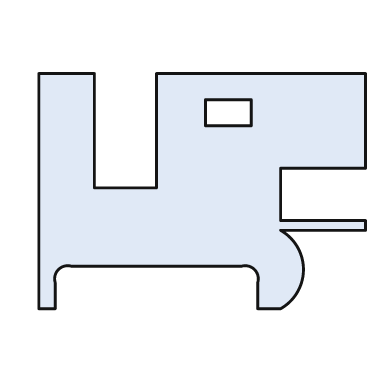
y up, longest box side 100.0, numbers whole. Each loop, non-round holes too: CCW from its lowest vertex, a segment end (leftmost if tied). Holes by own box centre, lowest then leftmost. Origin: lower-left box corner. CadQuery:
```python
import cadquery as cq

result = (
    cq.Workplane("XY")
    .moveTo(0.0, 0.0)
    .lineTo(5.0, 0.0)
    .lineTo(5.0, 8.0)
    .threePointArc((6.0, 12.0), (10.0, 13.0))
    .lineTo(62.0, 13.0)
    .threePointArc((66.0, 12.0), (67.0, 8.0))
    .lineTo(67.0, 0.0)
    .lineTo(74.0, 0.0)
    .threePointArc((81.0, 12.0), (74.0, 24.0))
    .lineTo(100.0, 24.0)
    .lineTo(100.0, 27.0)
    .lineTo(74.0, 27.0)
    .lineTo(74.0, 43.0)
    .lineTo(100.0, 43.0)
    .lineTo(100.0, 72.0)
    .lineTo(36.0, 72.0)
    .lineTo(36.0, 37.0)
    .lineTo(17.0, 37.0)
    .lineTo(17.0, 72.0)
    .lineTo(0.0, 72.0)
    .close()
    .moveTo(51.0, 56.0)
    .lineTo(65.0, 56.0)
    .lineTo(65.0, 64.0)
    .lineTo(51.0, 64.0)
    .close()
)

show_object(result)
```